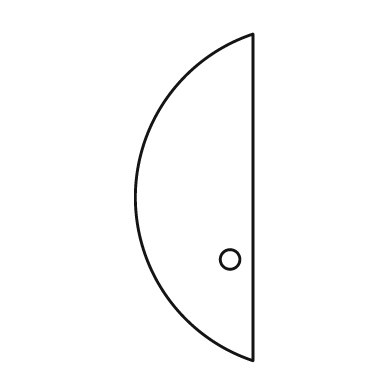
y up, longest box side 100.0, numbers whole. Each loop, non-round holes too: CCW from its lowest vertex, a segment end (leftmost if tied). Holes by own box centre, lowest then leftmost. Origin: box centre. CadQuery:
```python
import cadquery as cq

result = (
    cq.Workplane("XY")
    .moveTo(18.0, -50.0)
    .lineTo(18.0, 50.0)
    .threePointArc((-18.0, 0.0), (18.0, -50.0))
    .close()
    .moveTo(11.0, -19.0)
    .circle(3.0)
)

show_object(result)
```